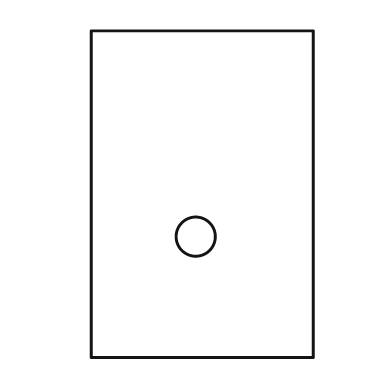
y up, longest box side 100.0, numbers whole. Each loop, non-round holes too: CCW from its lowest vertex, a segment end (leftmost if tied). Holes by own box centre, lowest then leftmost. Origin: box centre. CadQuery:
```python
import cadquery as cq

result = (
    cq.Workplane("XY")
    .moveTo(-34.0, -50.0)
    .lineTo(34.0, -50.0)
    .lineTo(34.0, 50.0)
    .lineTo(-34.0, 50.0)
    .close()
    .moveTo(-2.0, -13.0)
    .circle(6.0)
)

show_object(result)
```